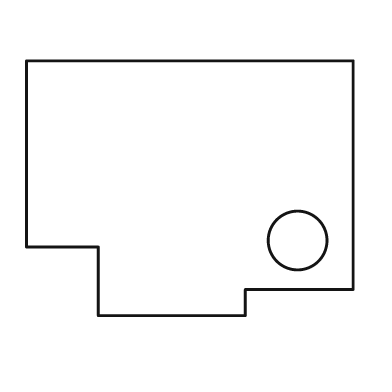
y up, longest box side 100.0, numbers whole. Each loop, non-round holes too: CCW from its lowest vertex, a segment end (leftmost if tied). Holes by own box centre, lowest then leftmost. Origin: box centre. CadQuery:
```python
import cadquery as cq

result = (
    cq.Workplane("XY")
    .moveTo(-28.0, -39.0)
    .lineTo(17.0, -39.0)
    .lineTo(17.0, -31.0)
    .lineTo(50.0, -31.0)
    .lineTo(50.0, 39.0)
    .lineTo(-50.0, 39.0)
    .lineTo(-50.0, -18.0)
    .lineTo(-28.0, -18.0)
    .close()
    .moveTo(33.0, -16.0)
    .circle(9.0)
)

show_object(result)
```